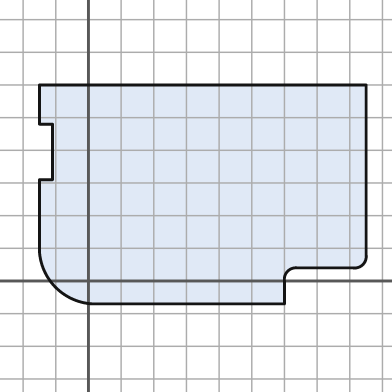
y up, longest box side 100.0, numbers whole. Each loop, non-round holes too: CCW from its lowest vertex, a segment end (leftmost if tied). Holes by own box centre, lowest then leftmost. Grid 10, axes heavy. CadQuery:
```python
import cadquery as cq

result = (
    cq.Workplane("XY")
    .moveTo(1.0, -7.0)
    .lineTo(60.0, -7.0)
    .lineTo(60.0, 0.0)
    .threePointArc((61.0, 3.0), (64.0, 4.0))
    .lineTo(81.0, 4.0)
    .threePointArc((84.0, 5.0), (85.0, 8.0))
    .lineTo(85.0, 60.0)
    .lineTo(-15.0, 60.0)
    .lineTo(-15.0, 48.0)
    .lineTo(-11.0, 48.0)
    .lineTo(-11.0, 31.0)
    .lineTo(-15.0, 31.0)
    .lineTo(-15.0, 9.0)
    .threePointArc((-10.0, -2.0), (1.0, -7.0))
    .close()
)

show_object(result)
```